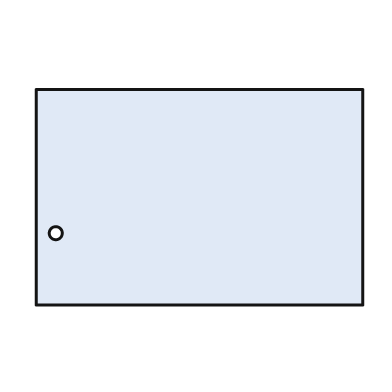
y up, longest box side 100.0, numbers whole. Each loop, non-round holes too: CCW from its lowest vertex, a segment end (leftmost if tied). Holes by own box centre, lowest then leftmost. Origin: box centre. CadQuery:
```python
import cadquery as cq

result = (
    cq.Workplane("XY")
    .moveTo(-50.0, -33.0)
    .lineTo(50.0, -33.0)
    .lineTo(50.0, 33.0)
    .lineTo(-50.0, 33.0)
    .close()
    .moveTo(-44.0, -11.0)
    .circle(2.0)
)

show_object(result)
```